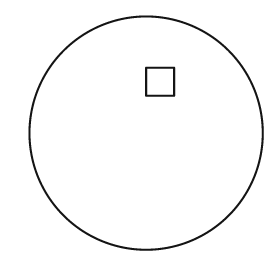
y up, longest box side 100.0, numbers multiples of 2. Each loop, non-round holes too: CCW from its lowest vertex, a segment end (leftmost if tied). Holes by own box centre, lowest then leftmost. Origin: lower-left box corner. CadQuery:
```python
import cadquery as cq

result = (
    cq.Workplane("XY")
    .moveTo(50.0, 50.0)
    .circle(50.0)
    .moveTo(50.0, 66.0)
    .lineTo(62.0, 66.0)
    .lineTo(62.0, 78.0)
    .lineTo(50.0, 78.0)
    .close()
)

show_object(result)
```